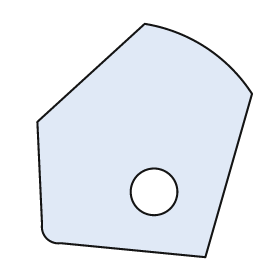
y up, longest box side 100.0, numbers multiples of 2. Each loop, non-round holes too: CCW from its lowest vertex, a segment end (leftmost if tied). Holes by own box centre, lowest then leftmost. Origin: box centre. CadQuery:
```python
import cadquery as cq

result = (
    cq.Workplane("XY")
    .moveTo(26.0, -50.0)
    .lineTo(46.0, 20.0)
    .threePointArc((26.0, 40.0), (0.0, 50.0))
    .lineTo(-46.0, 8.0)
    .lineTo(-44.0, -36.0)
    .threePointArc((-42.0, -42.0), (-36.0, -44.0))
    .close()
    .moveTo(4.0, -22.0)
    .circle(10.0)
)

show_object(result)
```